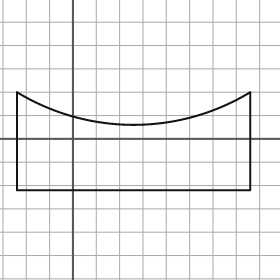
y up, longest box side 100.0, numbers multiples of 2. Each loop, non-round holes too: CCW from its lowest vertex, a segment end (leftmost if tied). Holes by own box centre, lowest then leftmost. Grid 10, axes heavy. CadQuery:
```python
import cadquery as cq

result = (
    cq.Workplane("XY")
    .moveTo(-24.0, -22.0)
    .lineTo(76.0, -22.0)
    .lineTo(76.0, 20.0)
    .threePointArc((26.0, 6.0), (-24.0, 20.0))
    .close()
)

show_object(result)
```